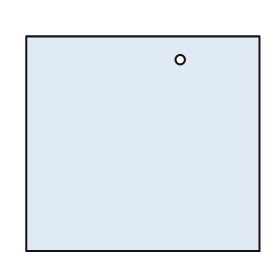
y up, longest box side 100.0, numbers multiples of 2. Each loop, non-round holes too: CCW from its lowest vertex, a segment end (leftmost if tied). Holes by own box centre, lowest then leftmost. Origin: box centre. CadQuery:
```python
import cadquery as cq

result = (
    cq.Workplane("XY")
    .moveTo(-50.0, -46.0)
    .lineTo(50.0, -46.0)
    .lineTo(50.0, 46.0)
    .lineTo(-50.0, 46.0)
    .close()
    .moveTo(16.0, 36.0)
    .circle(2.0)
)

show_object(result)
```